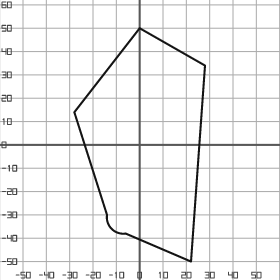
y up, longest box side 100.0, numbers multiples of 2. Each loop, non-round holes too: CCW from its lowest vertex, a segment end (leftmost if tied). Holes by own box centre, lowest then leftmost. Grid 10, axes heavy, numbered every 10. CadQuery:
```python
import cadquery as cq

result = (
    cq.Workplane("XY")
    .moveTo(22.0, -50.0)
    .lineTo(28.0, 34.0)
    .lineTo(0.0, 50.0)
    .lineTo(-28.0, 14.0)
    .lineTo(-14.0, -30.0)
    .threePointArc((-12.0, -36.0), (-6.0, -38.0))
    .close()
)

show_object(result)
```